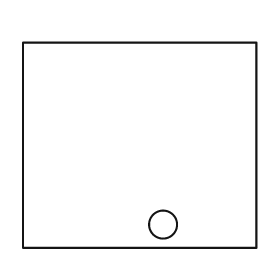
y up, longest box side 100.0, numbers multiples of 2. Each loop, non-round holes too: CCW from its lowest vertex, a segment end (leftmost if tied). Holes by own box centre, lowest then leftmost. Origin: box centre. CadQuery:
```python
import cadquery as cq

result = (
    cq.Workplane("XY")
    .moveTo(-50.0, -44.0)
    .lineTo(50.0, -44.0)
    .lineTo(50.0, 44.0)
    .lineTo(-50.0, 44.0)
    .close()
    .moveTo(10.0, -34.0)
    .circle(6.0)
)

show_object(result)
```